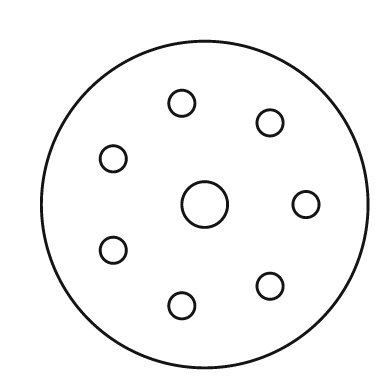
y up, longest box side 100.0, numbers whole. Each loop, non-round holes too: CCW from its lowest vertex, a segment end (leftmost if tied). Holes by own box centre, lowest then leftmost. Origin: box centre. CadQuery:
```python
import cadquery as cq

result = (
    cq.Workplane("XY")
    .moveTo(0.0, 0.0)
    .circle(50.0)
    .moveTo(-7.0, -31.0)
    .circle(4.0)
    .moveTo(20.0, -25.0)
    .circle(4.0)
    .moveTo(-28.0, -14.0)
    .circle(4.0)
    .moveTo(0.0, 0.0)
    .circle(7.0)
    .moveTo(31.0, 0.0)
    .circle(4.0)
    .moveTo(-28.0, 14.0)
    .circle(4.0)
    .moveTo(20.0, 25.0)
    .circle(4.0)
    .moveTo(-7.0, 31.0)
    .circle(4.0)
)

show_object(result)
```